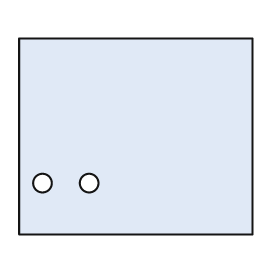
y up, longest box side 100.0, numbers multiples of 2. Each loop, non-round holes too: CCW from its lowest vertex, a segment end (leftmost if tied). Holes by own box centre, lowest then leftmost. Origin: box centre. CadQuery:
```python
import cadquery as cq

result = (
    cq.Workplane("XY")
    .moveTo(-50.0, -42.0)
    .lineTo(50.0, -42.0)
    .lineTo(50.0, 42.0)
    .lineTo(-50.0, 42.0)
    .close()
    .moveTo(-40.0, -20.0)
    .circle(4.0)
    .moveTo(-20.0, -20.0)
    .circle(4.0)
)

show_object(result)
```